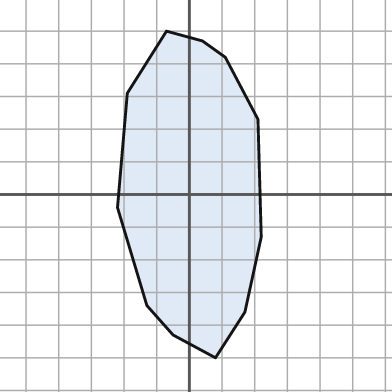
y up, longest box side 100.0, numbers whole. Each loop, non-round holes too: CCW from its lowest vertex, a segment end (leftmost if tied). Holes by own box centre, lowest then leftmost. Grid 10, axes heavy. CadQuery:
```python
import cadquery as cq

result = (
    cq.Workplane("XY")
    .moveTo(8.0, -50.0)
    .lineTo(17.0, -36.0)
    .lineTo(22.0, -13.0)
    .lineTo(21.0, 23.0)
    .lineTo(11.0, 42.0)
    .lineTo(4.0, 47.0)
    .lineTo(-7.0, 50.0)
    .lineTo(-19.0, 31.0)
    .lineTo(-22.0, -4.0)
    .lineTo(-13.0, -34.0)
    .lineTo(-5.0, -43.0)
    .close()
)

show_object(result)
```